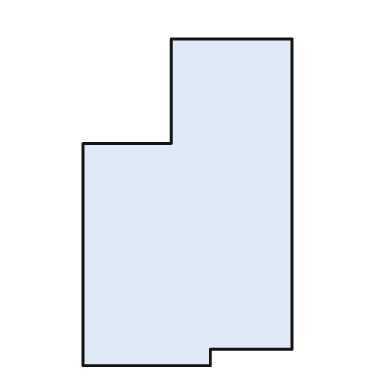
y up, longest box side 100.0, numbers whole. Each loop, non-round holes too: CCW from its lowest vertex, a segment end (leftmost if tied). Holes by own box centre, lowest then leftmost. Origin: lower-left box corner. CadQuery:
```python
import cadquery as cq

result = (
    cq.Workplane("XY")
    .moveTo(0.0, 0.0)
    .lineTo(39.0, 0.0)
    .lineTo(39.0, 5.0)
    .lineTo(64.0, 5.0)
    .lineTo(64.0, 100.0)
    .lineTo(27.0, 100.0)
    .lineTo(27.0, 68.0)
    .lineTo(0.0, 68.0)
    .close()
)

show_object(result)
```